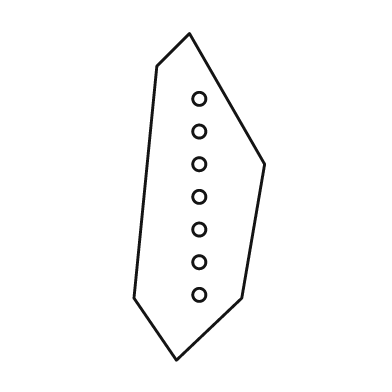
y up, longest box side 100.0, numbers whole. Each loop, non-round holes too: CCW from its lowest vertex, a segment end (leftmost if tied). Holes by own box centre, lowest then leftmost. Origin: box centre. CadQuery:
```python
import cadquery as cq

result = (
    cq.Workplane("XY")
    .moveTo(-7.0, -50.0)
    .lineTo(13.0, -31.0)
    .lineTo(20.0, 10.0)
    .lineTo(-3.0, 50.0)
    .lineTo(-13.0, 40.0)
    .lineTo(-20.0, -31.0)
    .close()
    .moveTo(0.0, -30.0)
    .circle(2.0)
    .moveTo(0.0, -20.0)
    .circle(2.0)
    .moveTo(0.0, -10.0)
    .circle(2.0)
    .moveTo(0.0, 0.0)
    .circle(2.0)
    .moveTo(0.0, 10.0)
    .circle(2.0)
    .moveTo(0.0, 20.0)
    .circle(2.0)
    .moveTo(0.0, 30.0)
    .circle(2.0)
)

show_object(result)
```